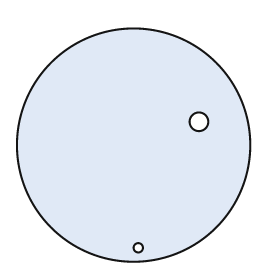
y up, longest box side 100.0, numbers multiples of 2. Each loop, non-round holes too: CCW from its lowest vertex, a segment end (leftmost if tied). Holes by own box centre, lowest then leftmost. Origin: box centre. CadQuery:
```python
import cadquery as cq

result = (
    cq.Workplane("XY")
    .moveTo(0.0, 0.0)
    .circle(50.0)
    .moveTo(2.0, -44.0)
    .circle(2.0)
    .moveTo(28.0, 10.0)
    .circle(4.0)
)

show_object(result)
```